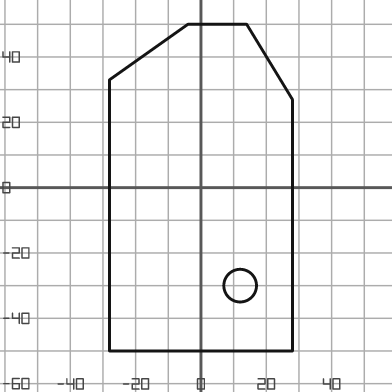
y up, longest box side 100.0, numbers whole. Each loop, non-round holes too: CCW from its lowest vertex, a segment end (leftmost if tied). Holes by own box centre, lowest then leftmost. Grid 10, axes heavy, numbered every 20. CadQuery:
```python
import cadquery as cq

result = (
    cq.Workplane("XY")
    .moveTo(-28.0, -50.0)
    .lineTo(28.0, -50.0)
    .lineTo(28.0, 27.0)
    .lineTo(14.0, 50.0)
    .lineTo(-4.0, 50.0)
    .lineTo(-28.0, 33.0)
    .close()
    .moveTo(12.0, -30.0)
    .circle(5.0)
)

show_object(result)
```